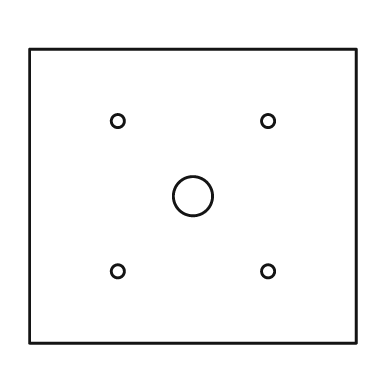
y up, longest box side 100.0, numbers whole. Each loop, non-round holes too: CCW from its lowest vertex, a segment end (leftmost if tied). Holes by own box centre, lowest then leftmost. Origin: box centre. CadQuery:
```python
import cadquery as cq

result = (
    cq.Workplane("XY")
    .moveTo(-50.0, -45.0)
    .lineTo(50.0, -45.0)
    .lineTo(50.0, 45.0)
    .lineTo(-50.0, 45.0)
    .close()
    .moveTo(-23.0, -23.0)
    .circle(2.0)
    .moveTo(23.0, -23.0)
    .circle(2.0)
    .moveTo(0.0, 0.0)
    .circle(6.0)
    .moveTo(-23.0, 23.0)
    .circle(2.0)
    .moveTo(23.0, 23.0)
    .circle(2.0)
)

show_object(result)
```